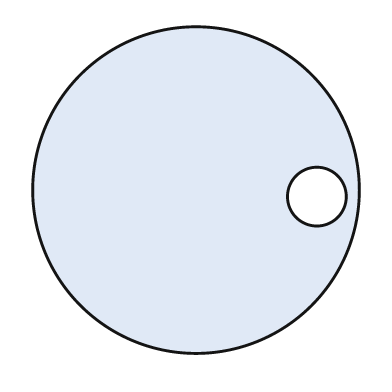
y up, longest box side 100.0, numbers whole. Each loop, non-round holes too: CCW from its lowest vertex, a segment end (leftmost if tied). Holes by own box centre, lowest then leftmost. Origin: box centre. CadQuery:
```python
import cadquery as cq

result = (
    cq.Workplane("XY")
    .moveTo(0.0, 0.0)
    .circle(50.0)
    .moveTo(37.0, -2.0)
    .circle(9.0)
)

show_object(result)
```